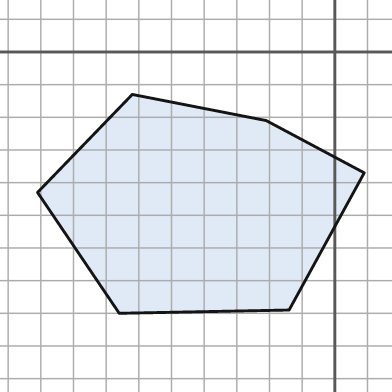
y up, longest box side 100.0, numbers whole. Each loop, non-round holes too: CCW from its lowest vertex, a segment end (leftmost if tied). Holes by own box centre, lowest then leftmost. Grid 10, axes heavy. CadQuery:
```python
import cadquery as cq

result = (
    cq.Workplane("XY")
    .moveTo(-66.0, -80.0)
    .lineTo(-14.0, -79.0)
    .lineTo(9.0, -37.0)
    .lineTo(-21.0, -21.0)
    .lineTo(-62.0, -13.0)
    .lineTo(-91.0, -43.0)
    .close()
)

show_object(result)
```